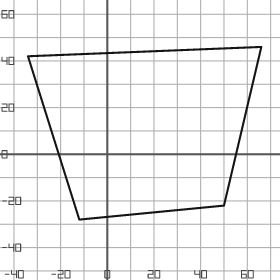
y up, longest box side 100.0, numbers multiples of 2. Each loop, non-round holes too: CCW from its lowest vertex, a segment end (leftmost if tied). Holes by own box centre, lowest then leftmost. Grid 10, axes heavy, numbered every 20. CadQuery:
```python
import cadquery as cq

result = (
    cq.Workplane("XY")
    .moveTo(-12.0, -28.0)
    .lineTo(50.0, -22.0)
    .lineTo(66.0, 46.0)
    .lineTo(-34.0, 42.0)
    .close()
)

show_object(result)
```